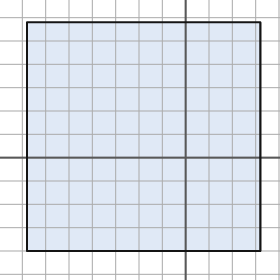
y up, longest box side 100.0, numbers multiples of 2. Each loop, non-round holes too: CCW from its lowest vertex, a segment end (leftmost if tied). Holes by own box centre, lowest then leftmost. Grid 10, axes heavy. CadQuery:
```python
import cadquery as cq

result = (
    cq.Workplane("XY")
    .moveTo(-68.0, -40.0)
    .lineTo(32.0, -40.0)
    .lineTo(32.0, 58.0)
    .lineTo(-68.0, 58.0)
    .close()
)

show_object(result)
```